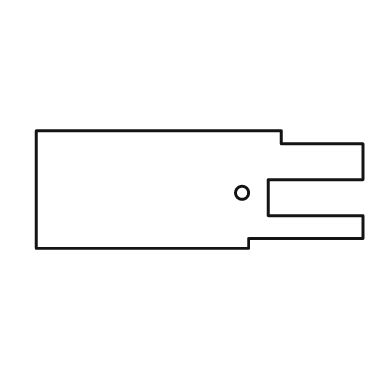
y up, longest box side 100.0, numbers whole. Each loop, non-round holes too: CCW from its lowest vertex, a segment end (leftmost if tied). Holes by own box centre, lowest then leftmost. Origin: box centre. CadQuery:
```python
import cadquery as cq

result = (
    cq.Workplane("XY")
    .moveTo(-50.0, -18.0)
    .lineTo(15.0, -18.0)
    .lineTo(15.0, -15.0)
    .lineTo(50.0, -15.0)
    .lineTo(50.0, -8.0)
    .lineTo(21.0, -8.0)
    .lineTo(21.0, 3.0)
    .lineTo(50.0, 3.0)
    .lineTo(50.0, 14.0)
    .lineTo(25.0, 14.0)
    .lineTo(25.0, 18.0)
    .lineTo(-50.0, 18.0)
    .close()
    .moveTo(13.0, -1.0)
    .circle(2.0)
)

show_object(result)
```